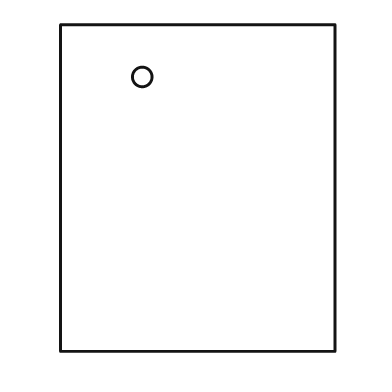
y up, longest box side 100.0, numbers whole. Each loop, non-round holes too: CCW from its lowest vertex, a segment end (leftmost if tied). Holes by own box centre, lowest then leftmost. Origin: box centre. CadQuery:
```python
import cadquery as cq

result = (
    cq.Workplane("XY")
    .moveTo(-42.0, -50.0)
    .lineTo(42.0, -50.0)
    .lineTo(42.0, 50.0)
    .lineTo(-42.0, 50.0)
    .close()
    .moveTo(-17.0, 34.0)
    .circle(3.0)
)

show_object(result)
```